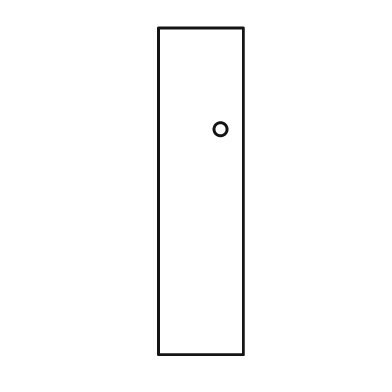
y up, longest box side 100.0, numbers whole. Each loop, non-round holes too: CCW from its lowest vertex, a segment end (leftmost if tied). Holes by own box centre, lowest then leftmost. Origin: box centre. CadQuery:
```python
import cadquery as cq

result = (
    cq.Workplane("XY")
    .moveTo(-13.0, -50.0)
    .lineTo(13.0, -50.0)
    .lineTo(13.0, 50.0)
    .lineTo(-13.0, 50.0)
    .close()
    .moveTo(6.0, 19.0)
    .circle(2.0)
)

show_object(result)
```